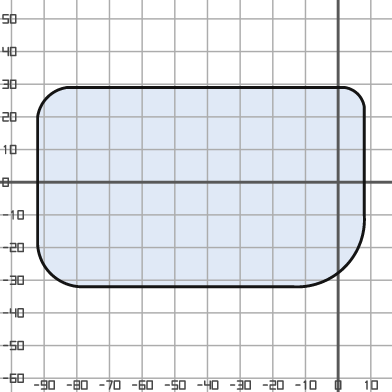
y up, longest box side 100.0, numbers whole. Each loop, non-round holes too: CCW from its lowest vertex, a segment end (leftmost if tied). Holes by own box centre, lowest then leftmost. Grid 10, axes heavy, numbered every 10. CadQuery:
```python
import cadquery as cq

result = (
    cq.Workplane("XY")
    .moveTo(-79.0, -32.0)
    .lineTo(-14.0, -32.0)
    .threePointArc((2.0, -26.0), (8.0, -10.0))
    .lineTo(8.0, 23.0)
    .threePointArc((6.0, 27.0), (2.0, 29.0))
    .lineTo(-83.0, 29.0)
    .threePointArc((-89.0, 26.0), (-92.0, 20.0))
    .lineTo(-92.0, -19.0)
    .threePointArc((-88.0, -28.0), (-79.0, -32.0))
    .close()
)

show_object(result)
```